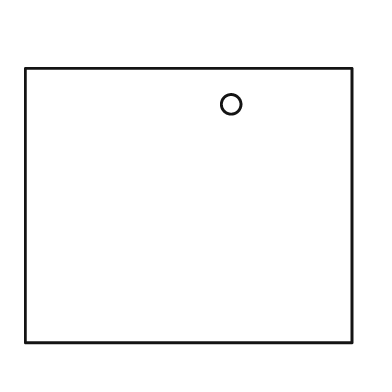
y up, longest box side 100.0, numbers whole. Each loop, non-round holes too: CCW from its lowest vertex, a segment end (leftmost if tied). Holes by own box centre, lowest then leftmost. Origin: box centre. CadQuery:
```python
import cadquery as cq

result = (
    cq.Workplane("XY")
    .moveTo(-50.0, -42.0)
    .lineTo(50.0, -42.0)
    .lineTo(50.0, 42.0)
    .lineTo(-50.0, 42.0)
    .close()
    .moveTo(13.0, 31.0)
    .circle(3.0)
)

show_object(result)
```